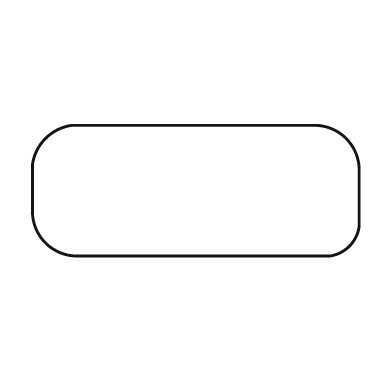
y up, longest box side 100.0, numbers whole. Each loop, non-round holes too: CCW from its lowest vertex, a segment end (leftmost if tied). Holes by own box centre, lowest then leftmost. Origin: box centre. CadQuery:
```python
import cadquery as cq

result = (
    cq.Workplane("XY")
    .moveTo(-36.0, -20.0)
    .lineTo(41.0, -20.0)
    .threePointArc((47.0, -17.0), (50.0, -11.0))
    .lineTo(50.0, 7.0)
    .threePointArc((46.0, 16.0), (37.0, 20.0))
    .lineTo(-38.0, 20.0)
    .threePointArc((-46.0, 16.0), (-50.0, 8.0))
    .lineTo(-50.0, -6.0)
    .threePointArc((-46.0, -16.0), (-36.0, -20.0))
    .close()
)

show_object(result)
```